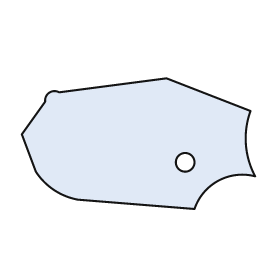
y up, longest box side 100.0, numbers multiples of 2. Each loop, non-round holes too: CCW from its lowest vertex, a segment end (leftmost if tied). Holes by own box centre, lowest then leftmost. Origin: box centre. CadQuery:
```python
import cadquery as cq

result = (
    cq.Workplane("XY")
    .moveTo(24.0, -28.0)
    .threePointArc((34.0, -16.0), (50.0, -14.0))
    .threePointArc((46.0, 0.0), (48.0, 14.0))
    .lineTo(12.0, 28.0)
    .lineTo(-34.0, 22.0)
    .threePointArc((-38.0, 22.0), (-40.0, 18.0))
    .lineTo(-50.0, 4.0)
    .lineTo(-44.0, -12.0)
    .threePointArc((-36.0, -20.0), (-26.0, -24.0))
    .close()
    .moveTo(20.0, -8.0)
    .circle(4.0)
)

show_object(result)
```